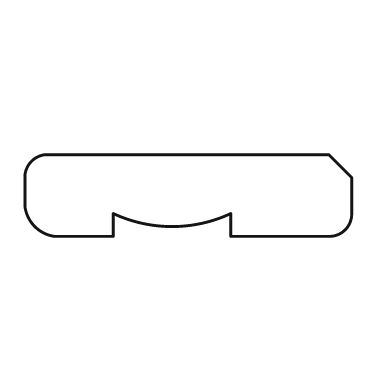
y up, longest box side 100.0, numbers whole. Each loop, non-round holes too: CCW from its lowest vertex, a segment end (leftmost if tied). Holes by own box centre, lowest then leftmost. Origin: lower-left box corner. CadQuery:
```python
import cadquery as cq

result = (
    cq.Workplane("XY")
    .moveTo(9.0, 0.0)
    .lineTo(27.0, 0.0)
    .lineTo(27.0, 7.0)
    .threePointArc((45.0, 3.0), (63.0, 7.0))
    .lineTo(63.0, 0.0)
    .lineTo(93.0, 0.0)
    .threePointArc((98.0, 2.0), (100.0, 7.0))
    .lineTo(100.0, 18.0)
    .lineTo(93.0, 25.0)
    .lineTo(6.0, 25.0)
    .threePointArc((2.0, 23.0), (0.0, 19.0))
    .lineTo(0.0, 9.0)
    .threePointArc((3.0, 3.0), (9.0, 0.0))
    .close()
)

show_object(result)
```